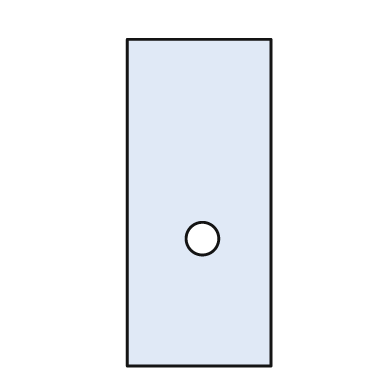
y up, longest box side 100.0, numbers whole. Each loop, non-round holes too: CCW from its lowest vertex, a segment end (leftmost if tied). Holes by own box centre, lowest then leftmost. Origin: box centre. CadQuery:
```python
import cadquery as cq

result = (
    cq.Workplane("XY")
    .moveTo(-22.0, -50.0)
    .lineTo(22.0, -50.0)
    .lineTo(22.0, 50.0)
    .lineTo(-22.0, 50.0)
    .close()
    .moveTo(1.0, -11.0)
    .circle(5.0)
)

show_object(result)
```